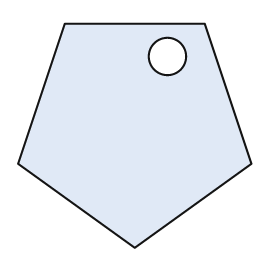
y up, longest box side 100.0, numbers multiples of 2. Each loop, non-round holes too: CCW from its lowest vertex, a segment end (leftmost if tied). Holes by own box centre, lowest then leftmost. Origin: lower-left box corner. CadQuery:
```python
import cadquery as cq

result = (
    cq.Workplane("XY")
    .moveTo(50.0, 0.0)
    .lineTo(100.0, 36.0)
    .lineTo(80.0, 96.0)
    .lineTo(20.0, 96.0)
    .lineTo(0.0, 36.0)
    .close()
    .moveTo(64.0, 82.0)
    .circle(8.0)
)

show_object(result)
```